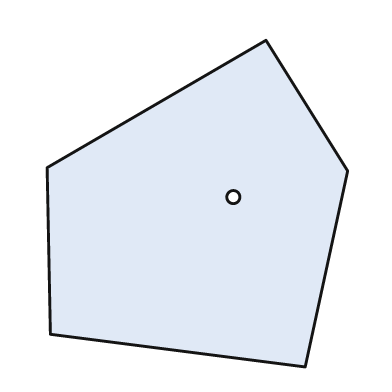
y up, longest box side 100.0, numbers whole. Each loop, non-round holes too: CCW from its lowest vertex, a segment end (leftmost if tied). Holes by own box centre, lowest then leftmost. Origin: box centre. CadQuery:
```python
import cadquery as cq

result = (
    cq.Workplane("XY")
    .moveTo(33.0, -50.0)
    .lineTo(46.0, 10.0)
    .lineTo(21.0, 50.0)
    .lineTo(-46.0, 11.0)
    .lineTo(-45.0, -40.0)
    .close()
    .moveTo(11.0, 2.0)
    .circle(2.0)
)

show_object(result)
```